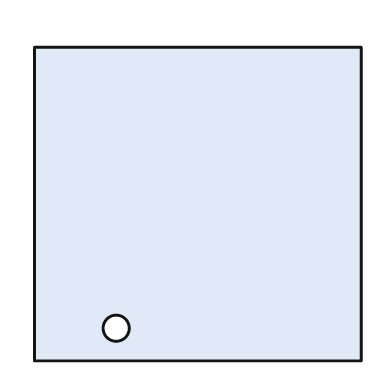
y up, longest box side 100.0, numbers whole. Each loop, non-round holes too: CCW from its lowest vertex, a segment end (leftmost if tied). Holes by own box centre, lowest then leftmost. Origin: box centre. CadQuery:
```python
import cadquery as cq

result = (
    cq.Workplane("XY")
    .moveTo(-50.0, -48.0)
    .lineTo(50.0, -48.0)
    .lineTo(50.0, 48.0)
    .lineTo(-50.0, 48.0)
    .close()
    .moveTo(-25.0, -38.0)
    .circle(4.0)
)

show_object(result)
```